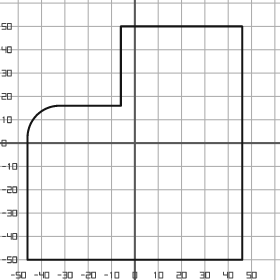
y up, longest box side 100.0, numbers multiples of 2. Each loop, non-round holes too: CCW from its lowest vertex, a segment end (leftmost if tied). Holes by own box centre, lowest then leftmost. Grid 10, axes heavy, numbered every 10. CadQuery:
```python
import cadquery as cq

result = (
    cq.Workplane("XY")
    .moveTo(-46.0, -50.0)
    .lineTo(46.0, -50.0)
    .lineTo(46.0, 50.0)
    .lineTo(-6.0, 50.0)
    .lineTo(-6.0, 16.0)
    .lineTo(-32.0, 16.0)
    .threePointArc((-42.0, 12.0), (-46.0, 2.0))
    .close()
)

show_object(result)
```